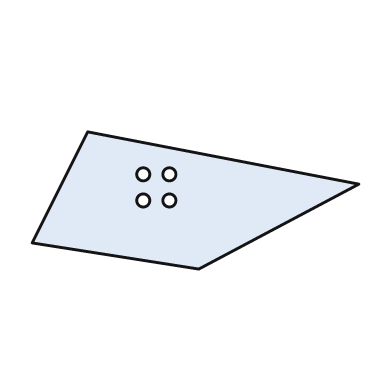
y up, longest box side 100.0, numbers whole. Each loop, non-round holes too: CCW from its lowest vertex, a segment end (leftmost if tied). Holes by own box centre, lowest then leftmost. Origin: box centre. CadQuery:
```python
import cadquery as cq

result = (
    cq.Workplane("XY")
    .moveTo(1.0, -21.0)
    .lineTo(50.0, 5.0)
    .lineTo(-33.0, 21.0)
    .lineTo(-50.0, -13.0)
    .close()
    .moveTo(-16.0, 0.0)
    .circle(2.0)
    .moveTo(-8.0, 0.0)
    .circle(2.0)
    .moveTo(-16.0, 8.0)
    .circle(2.0)
    .moveTo(-8.0, 8.0)
    .circle(2.0)
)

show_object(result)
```